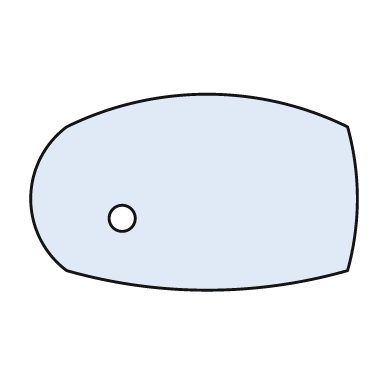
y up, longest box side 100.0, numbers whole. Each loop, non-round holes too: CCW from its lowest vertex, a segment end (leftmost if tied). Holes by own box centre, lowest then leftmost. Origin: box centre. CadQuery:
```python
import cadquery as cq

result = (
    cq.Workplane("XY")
    .moveTo(-39.0, -24.0)
    .threePointArc((4.0, -30.0), (47.0, -24.0))
    .threePointArc((50.0, -2.0), (47.0, 20.0))
    .threePointArc((4.0, 30.0), (-39.0, 20.0))
    .threePointArc((-50.0, -2.0), (-39.0, -24.0))
    .close()
    .moveTo(-22.0, -8.0)
    .circle(4.0)
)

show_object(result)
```